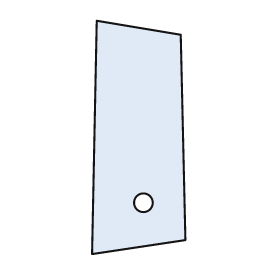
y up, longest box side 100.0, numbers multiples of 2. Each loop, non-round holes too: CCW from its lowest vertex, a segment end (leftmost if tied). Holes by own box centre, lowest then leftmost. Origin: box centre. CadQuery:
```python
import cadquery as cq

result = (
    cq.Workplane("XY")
    .moveTo(-20.0, -50.0)
    .lineTo(20.0, -44.0)
    .lineTo(18.0, 44.0)
    .lineTo(-18.0, 50.0)
    .close()
    .moveTo(2.0, -28.0)
    .circle(4.0)
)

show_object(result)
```